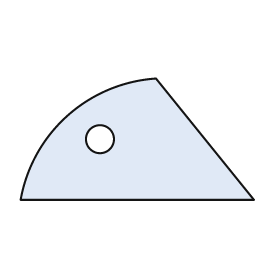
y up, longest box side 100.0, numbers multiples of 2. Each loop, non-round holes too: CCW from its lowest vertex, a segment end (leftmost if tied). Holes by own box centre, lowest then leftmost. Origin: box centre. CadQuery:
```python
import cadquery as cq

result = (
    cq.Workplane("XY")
    .moveTo(-50.0, -26.0)
    .lineTo(50.0, -26.0)
    .lineTo(8.0, 26.0)
    .threePointArc((-30.0, 10.0), (-50.0, -26.0))
    .close()
    .moveTo(-16.0, 0.0)
    .circle(6.0)
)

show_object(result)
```